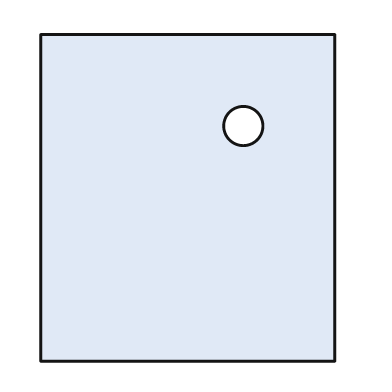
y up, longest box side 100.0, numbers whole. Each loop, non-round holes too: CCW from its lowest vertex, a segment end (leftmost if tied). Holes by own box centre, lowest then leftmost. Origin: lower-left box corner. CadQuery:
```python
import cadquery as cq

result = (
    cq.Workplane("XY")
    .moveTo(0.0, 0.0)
    .lineTo(90.0, 0.0)
    .lineTo(90.0, 100.0)
    .lineTo(0.0, 100.0)
    .close()
    .moveTo(62.0, 72.0)
    .circle(6.0)
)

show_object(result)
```